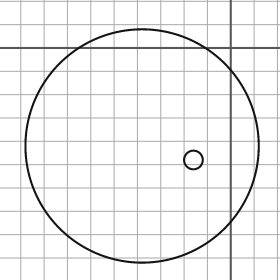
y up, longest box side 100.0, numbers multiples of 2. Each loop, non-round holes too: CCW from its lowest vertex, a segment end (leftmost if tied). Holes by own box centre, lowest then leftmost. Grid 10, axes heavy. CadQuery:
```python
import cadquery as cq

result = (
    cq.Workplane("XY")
    .moveTo(-38.0, -42.0)
    .circle(50.0)
    .moveTo(-16.0, -48.0)
    .circle(4.0)
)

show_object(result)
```